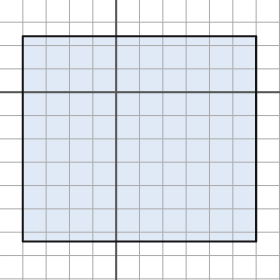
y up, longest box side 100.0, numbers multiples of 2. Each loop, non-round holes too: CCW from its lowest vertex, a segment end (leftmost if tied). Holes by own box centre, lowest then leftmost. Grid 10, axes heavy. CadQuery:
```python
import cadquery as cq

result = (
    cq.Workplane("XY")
    .moveTo(-40.0, -64.0)
    .lineTo(60.0, -64.0)
    .lineTo(60.0, 24.0)
    .lineTo(-40.0, 24.0)
    .close()
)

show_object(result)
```